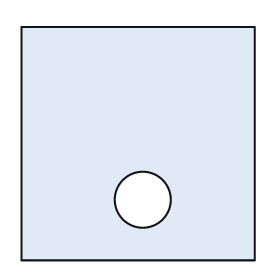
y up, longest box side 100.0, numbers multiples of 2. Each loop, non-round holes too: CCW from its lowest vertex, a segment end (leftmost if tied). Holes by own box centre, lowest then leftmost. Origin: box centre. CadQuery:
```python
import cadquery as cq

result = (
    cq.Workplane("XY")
    .moveTo(-50.0, -50.0)
    .lineTo(50.0, -50.0)
    .lineTo(50.0, 50.0)
    .lineTo(-50.0, 50.0)
    .close()
    .moveTo(2.0, -24.0)
    .circle(12.0)
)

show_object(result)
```